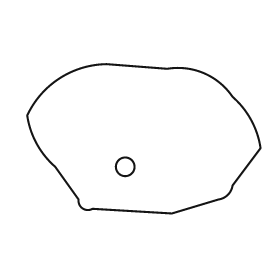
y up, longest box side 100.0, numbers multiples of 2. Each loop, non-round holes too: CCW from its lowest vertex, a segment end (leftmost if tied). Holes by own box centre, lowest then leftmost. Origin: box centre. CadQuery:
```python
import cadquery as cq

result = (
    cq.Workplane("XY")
    .moveTo(12.0, -32.0)
    .lineTo(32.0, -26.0)
    .threePointArc((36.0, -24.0), (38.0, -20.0))
    .lineTo(50.0, -4.0)
    .threePointArc((46.0, 8.0), (38.0, 18.0))
    .threePointArc((26.0, 28.0), (10.0, 30.0))
    .lineTo(-16.0, 32.0)
    .threePointArc((-36.0, 26.0), (-50.0, 10.0))
    .threePointArc((-46.0, -2.0), (-38.0, -12.0))
    .lineTo(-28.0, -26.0)
    .threePointArc((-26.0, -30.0), (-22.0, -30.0))
    .close()
    .moveTo(-8.0, -12.0)
    .circle(4.0)
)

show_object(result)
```